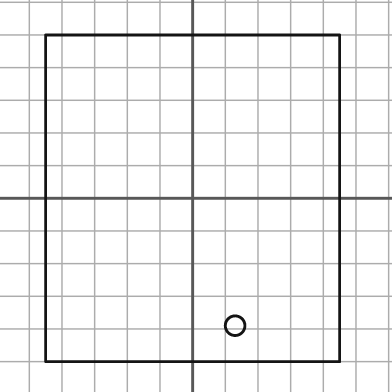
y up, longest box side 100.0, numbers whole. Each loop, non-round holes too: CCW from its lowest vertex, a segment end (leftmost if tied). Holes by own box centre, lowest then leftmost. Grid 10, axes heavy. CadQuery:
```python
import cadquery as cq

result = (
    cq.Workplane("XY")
    .moveTo(-45.0, -50.0)
    .lineTo(45.0, -50.0)
    .lineTo(45.0, 50.0)
    .lineTo(-45.0, 50.0)
    .close()
    .moveTo(13.0, -39.0)
    .circle(3.0)
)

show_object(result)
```